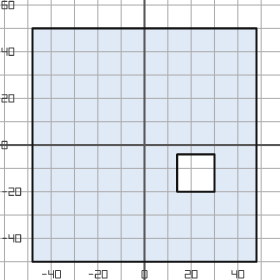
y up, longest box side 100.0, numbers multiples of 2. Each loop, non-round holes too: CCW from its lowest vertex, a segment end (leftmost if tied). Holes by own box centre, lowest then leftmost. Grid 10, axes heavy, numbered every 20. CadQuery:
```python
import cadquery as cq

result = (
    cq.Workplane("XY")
    .moveTo(-48.0, -50.0)
    .lineTo(48.0, -50.0)
    .lineTo(48.0, 50.0)
    .lineTo(-48.0, 50.0)
    .close()
    .moveTo(14.0, -20.0)
    .lineTo(30.0, -20.0)
    .lineTo(30.0, -4.0)
    .lineTo(14.0, -4.0)
    .close()
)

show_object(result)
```